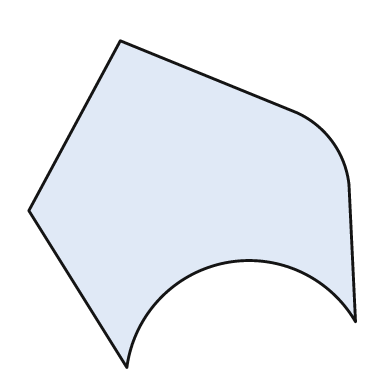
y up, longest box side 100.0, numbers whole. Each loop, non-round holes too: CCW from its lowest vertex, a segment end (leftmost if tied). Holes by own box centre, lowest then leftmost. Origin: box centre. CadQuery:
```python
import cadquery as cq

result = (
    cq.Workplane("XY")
    .moveTo(-20.0, -50.0)
    .threePointArc((10.0, -18.0), (50.0, -36.0))
    .lineTo(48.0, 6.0)
    .threePointArc((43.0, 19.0), (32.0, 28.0))
    .lineTo(-22.0, 50.0)
    .lineTo(-50.0, -2.0)
    .close()
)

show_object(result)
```